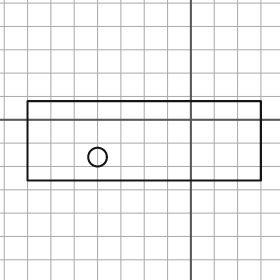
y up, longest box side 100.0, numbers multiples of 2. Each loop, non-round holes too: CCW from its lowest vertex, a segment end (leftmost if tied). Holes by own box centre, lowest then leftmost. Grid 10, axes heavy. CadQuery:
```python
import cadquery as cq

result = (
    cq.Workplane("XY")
    .moveTo(-70.0, -26.0)
    .lineTo(30.0, -26.0)
    .lineTo(30.0, 8.0)
    .lineTo(-70.0, 8.0)
    .close()
    .moveTo(-40.0, -16.0)
    .circle(4.0)
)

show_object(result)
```